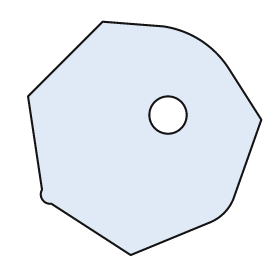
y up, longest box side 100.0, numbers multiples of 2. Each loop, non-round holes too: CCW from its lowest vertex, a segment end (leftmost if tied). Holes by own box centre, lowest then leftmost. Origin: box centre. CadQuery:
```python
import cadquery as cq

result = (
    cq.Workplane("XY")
    .moveTo(-6.0, -50.0)
    .lineTo(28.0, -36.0)
    .threePointArc((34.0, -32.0), (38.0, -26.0))
    .lineTo(50.0, 8.0)
    .lineTo(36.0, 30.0)
    .threePointArc((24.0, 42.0), (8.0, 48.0))
    .lineTo(-18.0, 50.0)
    .lineTo(-50.0, 18.0)
    .lineTo(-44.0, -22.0)
    .threePointArc((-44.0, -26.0), (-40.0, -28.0))
    .close()
    .moveTo(10.0, 10.0)
    .circle(8.0)
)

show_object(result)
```